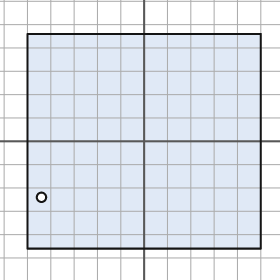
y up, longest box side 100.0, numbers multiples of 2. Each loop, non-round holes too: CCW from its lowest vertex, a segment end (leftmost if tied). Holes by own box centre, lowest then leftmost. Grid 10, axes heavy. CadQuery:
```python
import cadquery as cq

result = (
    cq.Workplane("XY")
    .moveTo(-50.0, -46.0)
    .lineTo(50.0, -46.0)
    .lineTo(50.0, 46.0)
    .lineTo(-50.0, 46.0)
    .close()
    .moveTo(-44.0, -24.0)
    .circle(2.0)
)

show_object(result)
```